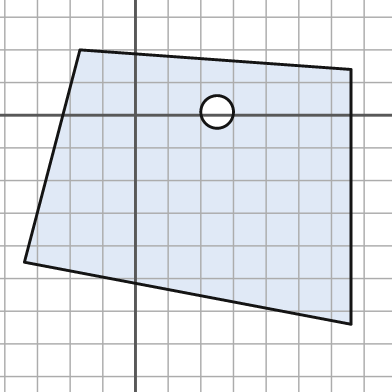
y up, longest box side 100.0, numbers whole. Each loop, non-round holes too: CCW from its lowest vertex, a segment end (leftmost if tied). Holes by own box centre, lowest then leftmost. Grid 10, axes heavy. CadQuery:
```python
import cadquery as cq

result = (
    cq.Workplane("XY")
    .moveTo(66.0, -64.0)
    .lineTo(66.0, 14.0)
    .lineTo(-17.0, 20.0)
    .lineTo(-34.0, -45.0)
    .close()
    .moveTo(25.0, 1.0)
    .circle(5.0)
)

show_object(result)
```